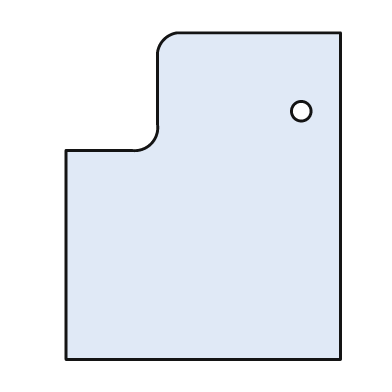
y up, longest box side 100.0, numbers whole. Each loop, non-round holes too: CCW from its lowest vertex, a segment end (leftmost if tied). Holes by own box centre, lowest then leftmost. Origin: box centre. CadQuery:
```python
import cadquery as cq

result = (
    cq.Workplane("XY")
    .moveTo(-42.0, -50.0)
    .lineTo(42.0, -50.0)
    .lineTo(42.0, 50.0)
    .lineTo(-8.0, 50.0)
    .threePointArc((-12.0, 48.0), (-14.0, 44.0))
    .lineTo(-14.0, 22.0)
    .threePointArc((-16.0, 16.0), (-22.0, 14.0))
    .lineTo(-42.0, 14.0)
    .close()
    .moveTo(30.0, 26.0)
    .circle(3.0)
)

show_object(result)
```